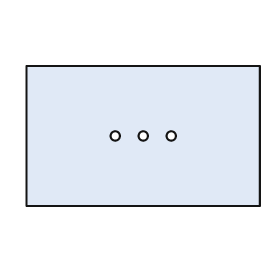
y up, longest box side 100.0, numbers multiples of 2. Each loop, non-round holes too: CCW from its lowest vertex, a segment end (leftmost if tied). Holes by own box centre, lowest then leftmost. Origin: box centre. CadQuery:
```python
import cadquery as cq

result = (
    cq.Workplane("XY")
    .moveTo(-50.0, -30.0)
    .lineTo(50.0, -30.0)
    .lineTo(50.0, 30.0)
    .lineTo(-50.0, 30.0)
    .close()
    .moveTo(-12.0, 0.0)
    .circle(2.0)
    .moveTo(0.0, 0.0)
    .circle(2.0)
    .moveTo(12.0, 0.0)
    .circle(2.0)
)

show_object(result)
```